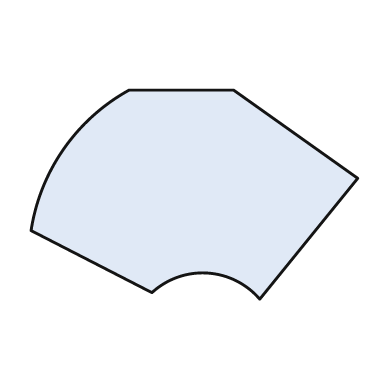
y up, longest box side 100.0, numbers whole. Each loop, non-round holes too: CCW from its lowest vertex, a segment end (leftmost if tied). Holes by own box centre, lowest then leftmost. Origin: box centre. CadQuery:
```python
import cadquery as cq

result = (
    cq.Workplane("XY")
    .moveTo(20.0, -32.0)
    .lineTo(50.0, 5.0)
    .lineTo(12.0, 32.0)
    .lineTo(-20.0, 32.0)
    .threePointArc((-40.0, 14.0), (-50.0, -11.0))
    .lineTo(-13.0, -30.0)
    .threePointArc((4.0, -24.0), (20.0, -32.0))
    .close()
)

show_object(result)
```